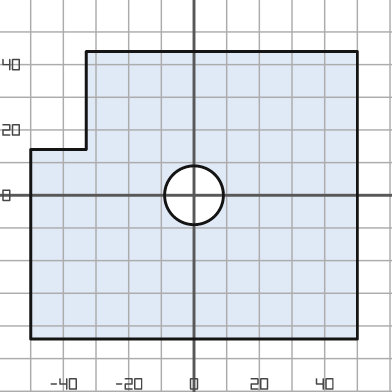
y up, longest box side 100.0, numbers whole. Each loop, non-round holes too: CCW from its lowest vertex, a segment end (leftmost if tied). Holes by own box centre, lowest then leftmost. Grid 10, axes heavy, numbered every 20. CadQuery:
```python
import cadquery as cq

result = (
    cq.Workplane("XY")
    .moveTo(-50.0, -44.0)
    .lineTo(50.0, -44.0)
    .lineTo(50.0, 44.0)
    .lineTo(-33.0, 44.0)
    .lineTo(-33.0, 14.0)
    .lineTo(-50.0, 14.0)
    .close()
    .moveTo(0.0, 0.0)
    .circle(9.0)
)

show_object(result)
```